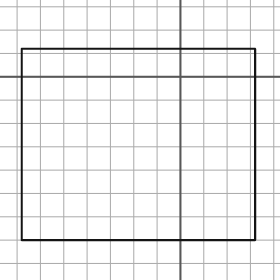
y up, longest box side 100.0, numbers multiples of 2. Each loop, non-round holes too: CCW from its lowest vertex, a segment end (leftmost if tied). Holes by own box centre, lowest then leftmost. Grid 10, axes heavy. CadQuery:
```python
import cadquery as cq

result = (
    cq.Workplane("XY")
    .moveTo(-68.0, -70.0)
    .lineTo(32.0, -70.0)
    .lineTo(32.0, 12.0)
    .lineTo(-68.0, 12.0)
    .close()
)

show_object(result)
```